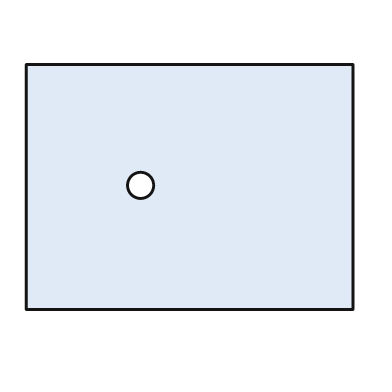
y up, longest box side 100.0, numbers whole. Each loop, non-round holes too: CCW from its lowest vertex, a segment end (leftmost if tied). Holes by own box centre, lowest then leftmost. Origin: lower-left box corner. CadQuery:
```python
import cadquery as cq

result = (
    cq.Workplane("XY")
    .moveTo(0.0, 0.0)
    .lineTo(100.0, 0.0)
    .lineTo(100.0, 75.0)
    .lineTo(0.0, 75.0)
    .close()
    .moveTo(35.0, 38.0)
    .circle(4.0)
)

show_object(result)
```